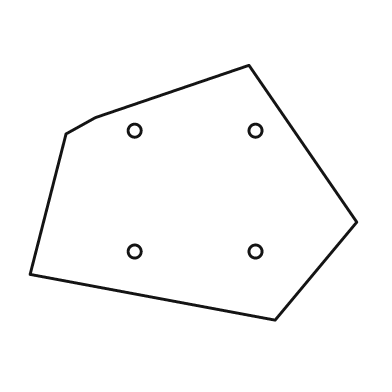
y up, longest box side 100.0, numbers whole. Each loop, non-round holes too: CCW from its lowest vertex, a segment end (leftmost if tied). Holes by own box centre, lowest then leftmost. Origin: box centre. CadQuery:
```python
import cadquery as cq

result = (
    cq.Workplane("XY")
    .moveTo(25.0, -39.0)
    .lineTo(50.0, -9.0)
    .lineTo(17.0, 39.0)
    .lineTo(-30.0, 23.0)
    .lineTo(-39.0, 18.0)
    .lineTo(-50.0, -25.0)
    .close()
    .moveTo(-18.0, -18.0)
    .circle(2.0)
    .moveTo(19.0, -18.0)
    .circle(2.0)
    .moveTo(-18.0, 19.0)
    .circle(2.0)
    .moveTo(19.0, 19.0)
    .circle(2.0)
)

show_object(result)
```